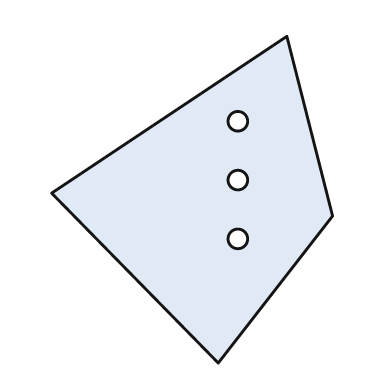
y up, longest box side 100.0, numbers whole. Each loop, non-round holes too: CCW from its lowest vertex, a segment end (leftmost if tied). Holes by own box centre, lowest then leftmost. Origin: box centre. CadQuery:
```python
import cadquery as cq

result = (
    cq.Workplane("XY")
    .moveTo(8.0, -50.0)
    .lineTo(43.0, -5.0)
    .lineTo(29.0, 50.0)
    .lineTo(-43.0, 2.0)
    .close()
    .moveTo(14.0, -12.0)
    .circle(3.0)
    .moveTo(14.0, 6.0)
    .circle(3.0)
    .moveTo(14.0, 24.0)
    .circle(3.0)
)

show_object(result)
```